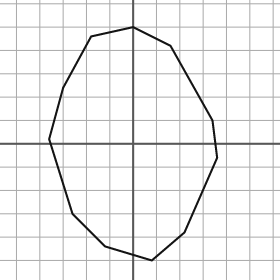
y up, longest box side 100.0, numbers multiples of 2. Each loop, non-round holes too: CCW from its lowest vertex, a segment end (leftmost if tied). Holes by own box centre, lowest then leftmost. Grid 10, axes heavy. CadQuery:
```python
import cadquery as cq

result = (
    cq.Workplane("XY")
    .moveTo(8.0, -50.0)
    .lineTo(22.0, -38.0)
    .lineTo(36.0, -6.0)
    .lineTo(34.0, 10.0)
    .lineTo(16.0, 42.0)
    .lineTo(0.0, 50.0)
    .lineTo(-18.0, 46.0)
    .lineTo(-30.0, 24.0)
    .lineTo(-36.0, 2.0)
    .lineTo(-26.0, -30.0)
    .lineTo(-12.0, -44.0)
    .close()
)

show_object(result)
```